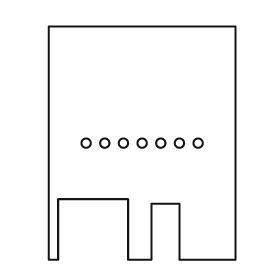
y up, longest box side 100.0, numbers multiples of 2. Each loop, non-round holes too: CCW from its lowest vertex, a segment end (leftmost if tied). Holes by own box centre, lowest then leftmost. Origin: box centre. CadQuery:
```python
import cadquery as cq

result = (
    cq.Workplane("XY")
    .moveTo(-40.0, -50.0)
    .lineTo(-36.0, -50.0)
    .lineTo(-36.0, -24.0)
    .lineTo(-6.0, -24.0)
    .lineTo(-6.0, -50.0)
    .lineTo(4.0, -50.0)
    .lineTo(4.0, -26.0)
    .lineTo(16.0, -26.0)
    .lineTo(16.0, -50.0)
    .lineTo(40.0, -50.0)
    .lineTo(40.0, 50.0)
    .lineTo(-40.0, 50.0)
    .close()
    .moveTo(-24.0, 0.0)
    .circle(2.0)
    .moveTo(-16.0, 0.0)
    .circle(2.0)
    .moveTo(-8.0, 0.0)
    .circle(2.0)
    .moveTo(0.0, 0.0)
    .circle(2.0)
    .moveTo(8.0, 0.0)
    .circle(2.0)
    .moveTo(16.0, 0.0)
    .circle(2.0)
    .moveTo(24.0, 0.0)
    .circle(2.0)
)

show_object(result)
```